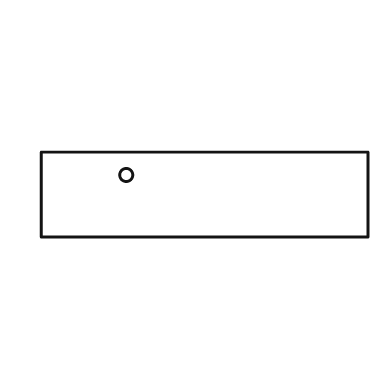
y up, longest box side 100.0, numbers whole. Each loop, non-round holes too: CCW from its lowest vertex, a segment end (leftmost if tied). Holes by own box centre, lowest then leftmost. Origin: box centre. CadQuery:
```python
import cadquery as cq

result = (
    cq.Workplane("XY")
    .moveTo(-50.0, -13.0)
    .lineTo(50.0, -13.0)
    .lineTo(50.0, 13.0)
    .lineTo(-50.0, 13.0)
    .close()
    .moveTo(-24.0, 6.0)
    .circle(2.0)
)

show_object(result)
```